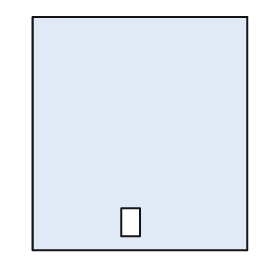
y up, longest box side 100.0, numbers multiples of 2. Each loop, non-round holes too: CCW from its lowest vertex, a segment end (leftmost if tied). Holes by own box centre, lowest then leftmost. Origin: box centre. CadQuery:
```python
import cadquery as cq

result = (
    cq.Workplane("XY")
    .moveTo(-46.0, -50.0)
    .lineTo(46.0, -50.0)
    .lineTo(46.0, 50.0)
    .lineTo(-46.0, 50.0)
    .close()
    .moveTo(-8.0, -44.0)
    .lineTo(0.0, -44.0)
    .lineTo(0.0, -32.0)
    .lineTo(-8.0, -32.0)
    .close()
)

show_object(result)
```